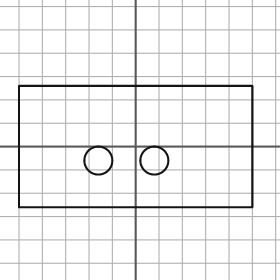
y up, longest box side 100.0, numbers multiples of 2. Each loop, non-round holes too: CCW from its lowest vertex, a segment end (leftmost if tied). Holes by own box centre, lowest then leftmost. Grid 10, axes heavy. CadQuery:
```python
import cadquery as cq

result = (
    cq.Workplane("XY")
    .moveTo(-50.0, -26.0)
    .lineTo(50.0, -26.0)
    .lineTo(50.0, 26.0)
    .lineTo(-50.0, 26.0)
    .close()
    .moveTo(-16.0, -6.0)
    .circle(6.0)
    .moveTo(8.0, -6.0)
    .circle(6.0)
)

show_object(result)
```